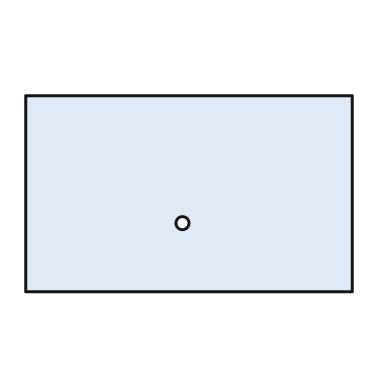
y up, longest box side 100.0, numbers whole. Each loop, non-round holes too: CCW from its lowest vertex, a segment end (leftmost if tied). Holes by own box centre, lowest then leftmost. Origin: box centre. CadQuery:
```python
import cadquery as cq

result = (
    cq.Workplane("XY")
    .moveTo(-50.0, -30.0)
    .lineTo(50.0, -30.0)
    .lineTo(50.0, 30.0)
    .lineTo(-50.0, 30.0)
    .close()
    .moveTo(-2.0, -9.0)
    .circle(2.0)
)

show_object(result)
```